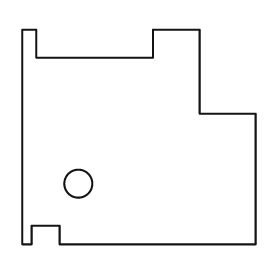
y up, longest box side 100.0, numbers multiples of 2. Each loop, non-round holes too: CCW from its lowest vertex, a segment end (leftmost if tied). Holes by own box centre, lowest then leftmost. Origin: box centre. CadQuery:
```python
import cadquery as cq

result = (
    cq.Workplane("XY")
    .moveTo(-50.0, -46.0)
    .lineTo(-46.0, -46.0)
    .lineTo(-46.0, -38.0)
    .lineTo(-34.0, -38.0)
    .lineTo(-34.0, -46.0)
    .lineTo(50.0, -46.0)
    .lineTo(50.0, 10.0)
    .lineTo(26.0, 10.0)
    .lineTo(26.0, 46.0)
    .lineTo(6.0, 46.0)
    .lineTo(6.0, 34.0)
    .lineTo(-44.0, 34.0)
    .lineTo(-44.0, 46.0)
    .lineTo(-50.0, 46.0)
    .close()
    .moveTo(-26.0, -20.0)
    .circle(6.0)
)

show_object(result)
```